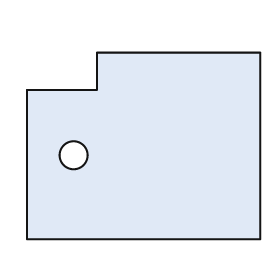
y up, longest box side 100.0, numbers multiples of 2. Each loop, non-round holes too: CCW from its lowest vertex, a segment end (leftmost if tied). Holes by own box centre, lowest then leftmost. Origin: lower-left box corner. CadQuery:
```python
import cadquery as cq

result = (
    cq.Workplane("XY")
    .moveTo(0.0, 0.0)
    .lineTo(100.0, 0.0)
    .lineTo(100.0, 80.0)
    .lineTo(30.0, 80.0)
    .lineTo(30.0, 64.0)
    .lineTo(0.0, 64.0)
    .close()
    .moveTo(20.0, 36.0)
    .circle(6.0)
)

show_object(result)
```